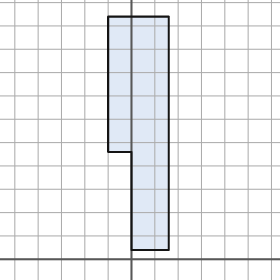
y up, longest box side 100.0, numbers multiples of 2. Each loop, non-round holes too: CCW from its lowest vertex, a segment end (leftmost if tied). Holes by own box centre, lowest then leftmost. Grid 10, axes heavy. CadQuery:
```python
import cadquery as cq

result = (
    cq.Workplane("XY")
    .moveTo(0.0, 4.0)
    .lineTo(16.0, 4.0)
    .lineTo(16.0, 104.0)
    .lineTo(-10.0, 104.0)
    .lineTo(-10.0, 46.0)
    .lineTo(0.0, 46.0)
    .close()
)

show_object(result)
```